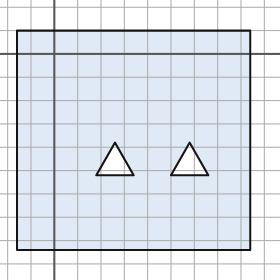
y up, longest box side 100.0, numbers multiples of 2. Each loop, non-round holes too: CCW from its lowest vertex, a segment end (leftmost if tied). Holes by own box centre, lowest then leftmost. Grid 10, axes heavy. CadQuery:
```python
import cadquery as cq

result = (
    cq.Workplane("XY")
    .moveTo(-16.0, -84.0)
    .lineTo(84.0, -84.0)
    .lineTo(84.0, 10.0)
    .lineTo(-16.0, 10.0)
    .close()
    .moveTo(18.0, -52.0)
    .lineTo(34.0, -52.0)
    .lineTo(26.0, -38.0)
    .close()
    .moveTo(50.0, -52.0)
    .lineTo(66.0, -52.0)
    .lineTo(58.0, -38.0)
    .close()
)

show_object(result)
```